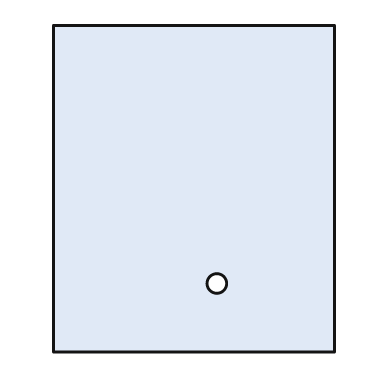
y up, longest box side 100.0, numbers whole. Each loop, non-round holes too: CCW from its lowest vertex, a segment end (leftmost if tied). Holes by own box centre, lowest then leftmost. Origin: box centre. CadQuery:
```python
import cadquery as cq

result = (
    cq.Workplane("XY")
    .moveTo(-43.0, -50.0)
    .lineTo(43.0, -50.0)
    .lineTo(43.0, 50.0)
    .lineTo(-43.0, 50.0)
    .close()
    .moveTo(7.0, -29.0)
    .circle(3.0)
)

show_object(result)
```